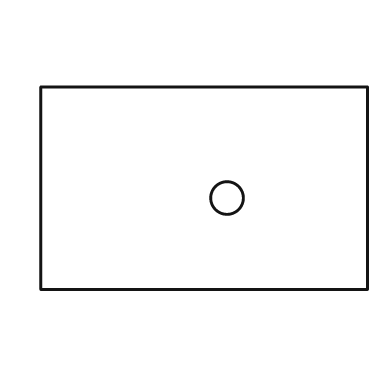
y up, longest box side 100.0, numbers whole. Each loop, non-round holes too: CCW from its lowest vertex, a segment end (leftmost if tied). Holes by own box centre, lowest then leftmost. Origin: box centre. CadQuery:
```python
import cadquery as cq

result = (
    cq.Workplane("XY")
    .moveTo(-50.0, -31.0)
    .lineTo(50.0, -31.0)
    .lineTo(50.0, 31.0)
    .lineTo(-50.0, 31.0)
    .close()
    .moveTo(7.0, -3.0)
    .circle(5.0)
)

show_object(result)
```